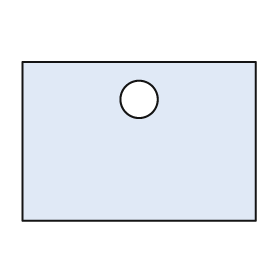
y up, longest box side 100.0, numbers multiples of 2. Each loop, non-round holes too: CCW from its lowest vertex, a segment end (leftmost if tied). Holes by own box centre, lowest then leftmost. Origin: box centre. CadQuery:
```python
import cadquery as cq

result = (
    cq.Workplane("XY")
    .moveTo(-50.0, -34.0)
    .lineTo(50.0, -34.0)
    .lineTo(50.0, 34.0)
    .lineTo(-50.0, 34.0)
    .close()
    .moveTo(0.0, 18.0)
    .circle(8.0)
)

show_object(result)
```